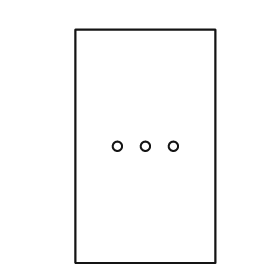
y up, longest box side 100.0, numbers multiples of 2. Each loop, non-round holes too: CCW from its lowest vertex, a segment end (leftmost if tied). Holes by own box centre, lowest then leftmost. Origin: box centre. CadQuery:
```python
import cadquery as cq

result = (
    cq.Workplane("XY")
    .moveTo(-30.0, -50.0)
    .lineTo(30.0, -50.0)
    .lineTo(30.0, 50.0)
    .lineTo(-30.0, 50.0)
    .close()
    .moveTo(-12.0, 0.0)
    .circle(2.0)
    .moveTo(0.0, 0.0)
    .circle(2.0)
    .moveTo(12.0, 0.0)
    .circle(2.0)
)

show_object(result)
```